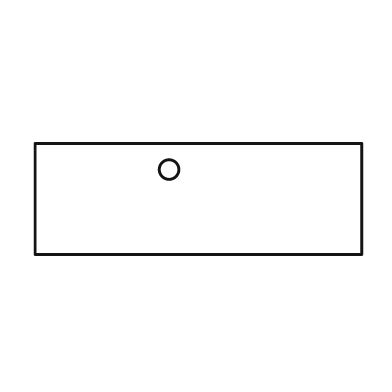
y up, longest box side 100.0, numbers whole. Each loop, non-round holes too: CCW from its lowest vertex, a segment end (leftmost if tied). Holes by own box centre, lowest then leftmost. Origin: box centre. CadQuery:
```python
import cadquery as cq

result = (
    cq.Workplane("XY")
    .moveTo(-50.0, -17.0)
    .lineTo(50.0, -17.0)
    .lineTo(50.0, 17.0)
    .lineTo(-50.0, 17.0)
    .close()
    .moveTo(-9.0, 9.0)
    .circle(3.0)
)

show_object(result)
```